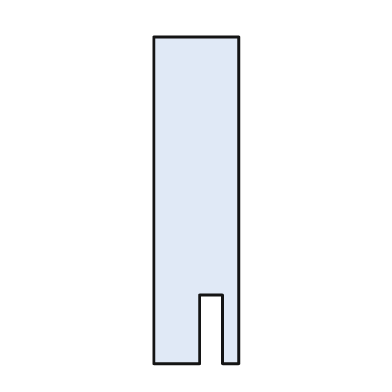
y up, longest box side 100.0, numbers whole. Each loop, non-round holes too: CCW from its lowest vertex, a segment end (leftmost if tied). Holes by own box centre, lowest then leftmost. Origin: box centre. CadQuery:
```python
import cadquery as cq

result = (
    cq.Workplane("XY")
    .moveTo(-13.0, -50.0)
    .lineTo(1.0, -50.0)
    .lineTo(1.0, -29.0)
    .lineTo(8.0, -29.0)
    .lineTo(8.0, -50.0)
    .lineTo(13.0, -50.0)
    .lineTo(13.0, 50.0)
    .lineTo(-13.0, 50.0)
    .close()
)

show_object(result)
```